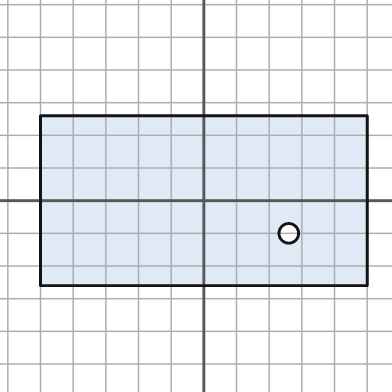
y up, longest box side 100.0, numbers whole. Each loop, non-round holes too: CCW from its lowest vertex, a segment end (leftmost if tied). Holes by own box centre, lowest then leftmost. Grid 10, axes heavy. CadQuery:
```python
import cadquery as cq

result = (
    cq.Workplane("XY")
    .moveTo(-50.0, -26.0)
    .lineTo(50.0, -26.0)
    .lineTo(50.0, 26.0)
    .lineTo(-50.0, 26.0)
    .close()
    .moveTo(26.0, -10.0)
    .circle(3.0)
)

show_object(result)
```